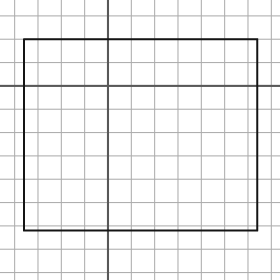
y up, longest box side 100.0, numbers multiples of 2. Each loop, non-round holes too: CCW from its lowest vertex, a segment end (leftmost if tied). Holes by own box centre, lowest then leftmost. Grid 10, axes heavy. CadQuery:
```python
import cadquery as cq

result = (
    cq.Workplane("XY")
    .moveTo(-36.0, -62.0)
    .lineTo(64.0, -62.0)
    .lineTo(64.0, 20.0)
    .lineTo(-36.0, 20.0)
    .close()
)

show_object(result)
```